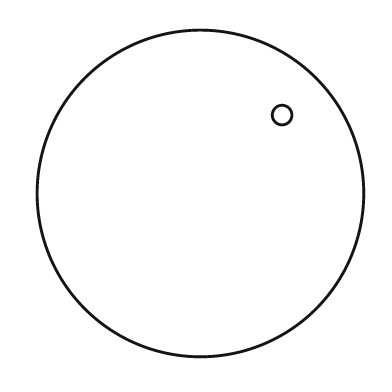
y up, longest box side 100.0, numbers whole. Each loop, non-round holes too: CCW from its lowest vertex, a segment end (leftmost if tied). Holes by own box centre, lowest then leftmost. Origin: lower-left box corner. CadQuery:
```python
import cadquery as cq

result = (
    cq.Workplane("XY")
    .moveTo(50.0, 50.0)
    .circle(50.0)
    .moveTo(75.0, 74.0)
    .circle(3.0)
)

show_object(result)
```